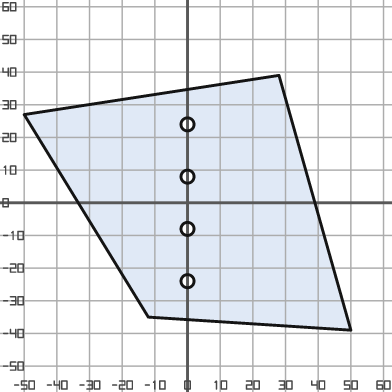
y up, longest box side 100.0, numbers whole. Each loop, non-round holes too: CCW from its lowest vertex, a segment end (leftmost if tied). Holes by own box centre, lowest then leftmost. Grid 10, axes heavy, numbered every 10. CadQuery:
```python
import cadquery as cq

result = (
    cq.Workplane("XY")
    .moveTo(50.0, -39.0)
    .lineTo(28.0, 39.0)
    .lineTo(-50.0, 27.0)
    .lineTo(-12.0, -35.0)
    .close()
    .moveTo(0.0, -24.0)
    .circle(2.0)
    .moveTo(0.0, -8.0)
    .circle(2.0)
    .moveTo(0.0, 8.0)
    .circle(2.0)
    .moveTo(0.0, 24.0)
    .circle(2.0)
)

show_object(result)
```